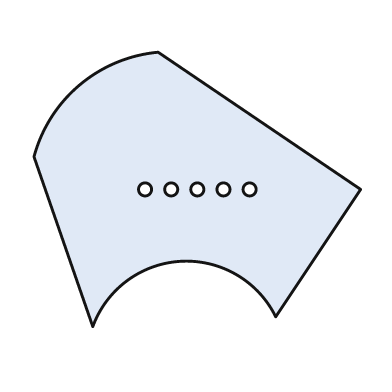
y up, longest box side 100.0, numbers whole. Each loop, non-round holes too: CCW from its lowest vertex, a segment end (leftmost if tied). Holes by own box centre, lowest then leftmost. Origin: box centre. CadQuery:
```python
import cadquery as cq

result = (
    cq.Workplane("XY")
    .moveTo(-32.0, -42.0)
    .threePointArc((-5.0, -22.0), (24.0, -39.0))
    .lineTo(50.0, 0.0)
    .lineTo(-12.0, 42.0)
    .threePointArc((-36.0, 32.0), (-50.0, 10.0))
    .close()
    .moveTo(-16.0, 0.0)
    .circle(2.0)
    .moveTo(-8.0, 0.0)
    .circle(2.0)
    .moveTo(0.0, 0.0)
    .circle(2.0)
    .moveTo(8.0, 0.0)
    .circle(2.0)
    .moveTo(16.0, 0.0)
    .circle(2.0)
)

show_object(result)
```